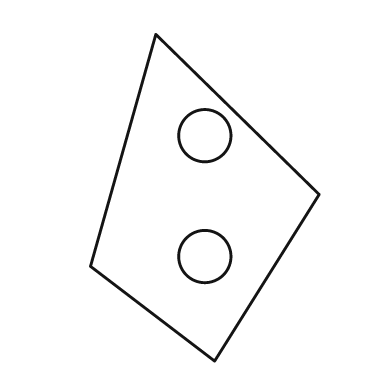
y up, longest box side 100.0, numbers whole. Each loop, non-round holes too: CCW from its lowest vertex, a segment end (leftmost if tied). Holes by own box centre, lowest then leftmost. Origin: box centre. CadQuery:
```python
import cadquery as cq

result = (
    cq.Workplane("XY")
    .moveTo(3.0, -50.0)
    .lineTo(35.0, 1.0)
    .lineTo(-15.0, 50.0)
    .lineTo(-35.0, -21.0)
    .close()
    .moveTo(0.0, -18.0)
    .circle(8.0)
    .moveTo(0.0, 19.0)
    .circle(8.0)
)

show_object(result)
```